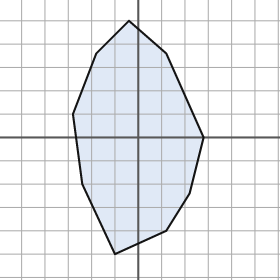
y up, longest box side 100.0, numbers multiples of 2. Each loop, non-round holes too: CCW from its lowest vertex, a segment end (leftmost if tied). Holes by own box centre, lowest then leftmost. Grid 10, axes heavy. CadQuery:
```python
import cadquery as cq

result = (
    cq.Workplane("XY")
    .moveTo(-10.0, -50.0)
    .lineTo(12.0, -40.0)
    .lineTo(22.0, -24.0)
    .lineTo(28.0, 0.0)
    .lineTo(12.0, 36.0)
    .lineTo(-4.0, 50.0)
    .lineTo(-18.0, 36.0)
    .lineTo(-28.0, 10.0)
    .lineTo(-24.0, -20.0)
    .close()
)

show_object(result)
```